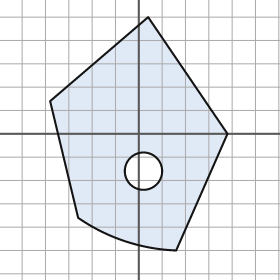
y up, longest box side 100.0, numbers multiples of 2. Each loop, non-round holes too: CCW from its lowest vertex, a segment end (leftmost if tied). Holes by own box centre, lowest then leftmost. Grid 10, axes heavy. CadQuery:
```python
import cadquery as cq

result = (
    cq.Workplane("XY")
    .moveTo(16.0, -50.0)
    .lineTo(38.0, 0.0)
    .lineTo(4.0, 50.0)
    .lineTo(-38.0, 14.0)
    .lineTo(-26.0, -36.0)
    .threePointArc((-6.0, -46.0), (16.0, -50.0))
    .close()
    .moveTo(2.0, -16.0)
    .circle(8.0)
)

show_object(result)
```